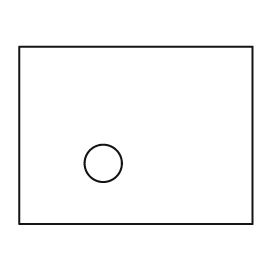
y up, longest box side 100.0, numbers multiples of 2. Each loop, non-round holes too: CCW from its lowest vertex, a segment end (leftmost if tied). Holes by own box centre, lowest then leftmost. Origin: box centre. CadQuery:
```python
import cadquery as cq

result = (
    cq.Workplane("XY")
    .moveTo(-50.0, -38.0)
    .lineTo(50.0, -38.0)
    .lineTo(50.0, 38.0)
    .lineTo(-50.0, 38.0)
    .close()
    .moveTo(-14.0, -12.0)
    .circle(8.0)
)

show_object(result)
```